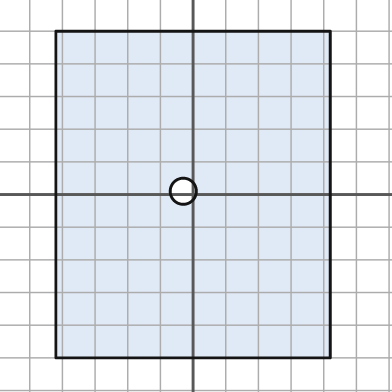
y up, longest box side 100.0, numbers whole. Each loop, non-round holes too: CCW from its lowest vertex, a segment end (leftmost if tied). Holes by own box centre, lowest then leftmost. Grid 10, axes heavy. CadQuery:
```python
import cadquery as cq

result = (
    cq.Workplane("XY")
    .moveTo(-42.0, -50.0)
    .lineTo(42.0, -50.0)
    .lineTo(42.0, 50.0)
    .lineTo(-42.0, 50.0)
    .close()
    .moveTo(-3.0, 1.0)
    .circle(4.0)
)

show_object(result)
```